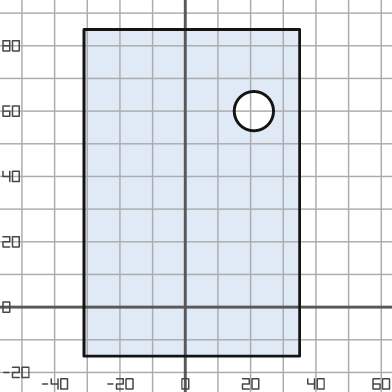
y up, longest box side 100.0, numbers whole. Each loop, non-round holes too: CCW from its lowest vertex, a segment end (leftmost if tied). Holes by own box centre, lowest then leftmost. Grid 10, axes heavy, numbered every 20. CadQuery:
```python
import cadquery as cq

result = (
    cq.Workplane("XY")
    .moveTo(-31.0, -15.0)
    .lineTo(35.0, -15.0)
    .lineTo(35.0, 85.0)
    .lineTo(-31.0, 85.0)
    .close()
    .moveTo(21.0, 60.0)
    .circle(6.0)
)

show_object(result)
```